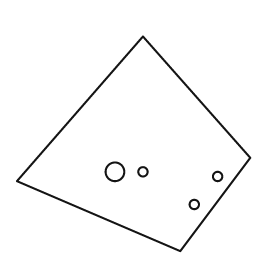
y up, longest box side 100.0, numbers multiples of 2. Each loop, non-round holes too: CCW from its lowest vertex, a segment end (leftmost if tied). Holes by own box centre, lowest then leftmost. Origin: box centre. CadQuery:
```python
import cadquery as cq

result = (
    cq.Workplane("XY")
    .moveTo(20.0, -46.0)
    .lineTo(50.0, -6.0)
    .lineTo(4.0, 46.0)
    .lineTo(-50.0, -16.0)
    .close()
    .moveTo(26.0, -26.0)
    .circle(2.0)
    .moveTo(36.0, -14.0)
    .circle(2.0)
    .moveTo(-8.0, -12.0)
    .circle(4.0)
    .moveTo(4.0, -12.0)
    .circle(2.0)
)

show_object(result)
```